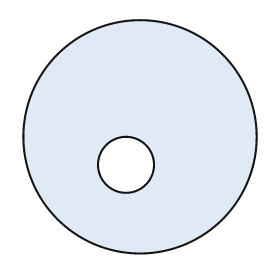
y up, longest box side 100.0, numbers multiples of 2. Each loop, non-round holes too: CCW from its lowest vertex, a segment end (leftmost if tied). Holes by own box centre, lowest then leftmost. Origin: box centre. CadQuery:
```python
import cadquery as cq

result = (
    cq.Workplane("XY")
    .moveTo(0.0, 0.0)
    .circle(50.0)
    .moveTo(-6.0, -12.0)
    .circle(12.0)
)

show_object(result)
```